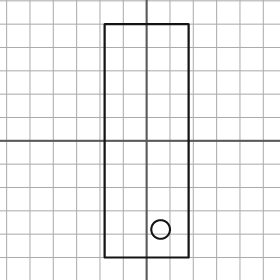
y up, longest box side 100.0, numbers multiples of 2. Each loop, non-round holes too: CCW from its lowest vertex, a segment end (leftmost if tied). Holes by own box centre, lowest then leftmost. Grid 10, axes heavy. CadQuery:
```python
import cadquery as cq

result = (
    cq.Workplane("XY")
    .moveTo(-18.0, -50.0)
    .lineTo(18.0, -50.0)
    .lineTo(18.0, 50.0)
    .lineTo(-18.0, 50.0)
    .close()
    .moveTo(6.0, -38.0)
    .circle(4.0)
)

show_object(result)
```